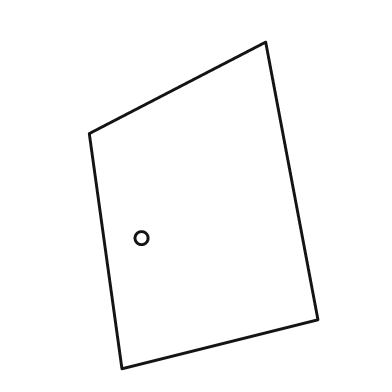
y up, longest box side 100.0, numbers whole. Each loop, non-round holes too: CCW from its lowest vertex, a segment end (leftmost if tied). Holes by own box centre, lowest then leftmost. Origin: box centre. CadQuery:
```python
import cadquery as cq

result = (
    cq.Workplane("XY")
    .moveTo(-25.0, -50.0)
    .lineTo(35.0, -35.0)
    .lineTo(19.0, 50.0)
    .lineTo(-35.0, 22.0)
    .close()
    .moveTo(-19.0, -10.0)
    .circle(2.0)
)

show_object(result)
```